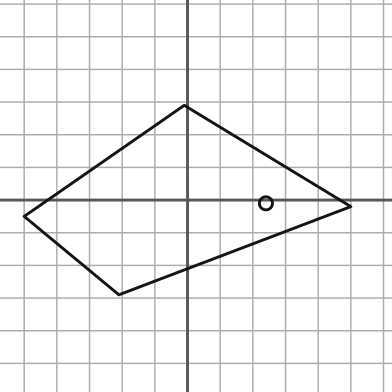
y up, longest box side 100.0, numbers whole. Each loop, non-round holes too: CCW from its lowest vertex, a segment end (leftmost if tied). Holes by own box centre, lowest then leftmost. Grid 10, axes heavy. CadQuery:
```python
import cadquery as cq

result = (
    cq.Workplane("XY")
    .moveTo(-21.0, -29.0)
    .lineTo(50.0, -2.0)
    .lineTo(-1.0, 29.0)
    .lineTo(-50.0, -5.0)
    .close()
    .moveTo(24.0, -1.0)
    .circle(2.0)
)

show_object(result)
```